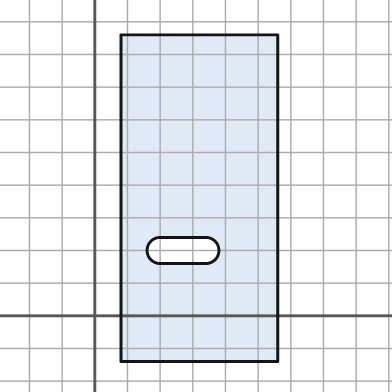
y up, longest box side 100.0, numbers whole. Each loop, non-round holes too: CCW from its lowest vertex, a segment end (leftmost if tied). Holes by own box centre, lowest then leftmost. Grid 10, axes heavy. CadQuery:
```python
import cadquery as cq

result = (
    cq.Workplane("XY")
    .moveTo(8.0, -14.0)
    .lineTo(56.0, -14.0)
    .lineTo(56.0, 86.0)
    .lineTo(8.0, 86.0)
    .close()
    .moveTo(20.0, 16.0)
    .lineTo(34.0, 16.0)
    .threePointArc((38.0, 20.0), (34.0, 24.0))
    .lineTo(20.0, 24.0)
    .threePointArc((16.0, 20.0), (20.0, 16.0))
    .close()
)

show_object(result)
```